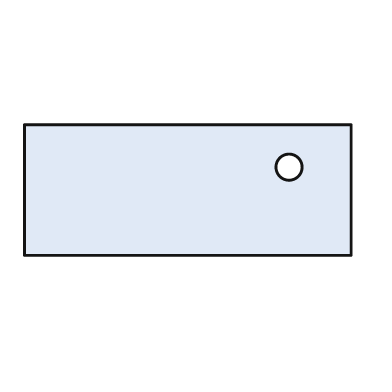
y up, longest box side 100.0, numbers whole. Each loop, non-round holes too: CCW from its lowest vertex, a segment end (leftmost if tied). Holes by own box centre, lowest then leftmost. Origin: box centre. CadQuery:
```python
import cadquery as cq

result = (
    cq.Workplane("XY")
    .moveTo(-50.0, -20.0)
    .lineTo(50.0, -20.0)
    .lineTo(50.0, 20.0)
    .lineTo(-50.0, 20.0)
    .close()
    .moveTo(31.0, 7.0)
    .circle(4.0)
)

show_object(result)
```